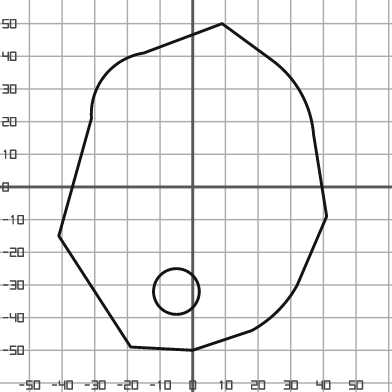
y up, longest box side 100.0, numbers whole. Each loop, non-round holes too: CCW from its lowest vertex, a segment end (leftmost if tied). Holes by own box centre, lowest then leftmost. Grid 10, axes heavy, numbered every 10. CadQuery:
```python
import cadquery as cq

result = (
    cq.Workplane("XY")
    .moveTo(0.0, -50.0)
    .lineTo(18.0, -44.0)
    .threePointArc((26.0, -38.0), (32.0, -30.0))
    .lineTo(41.0, -9.0)
    .lineTo(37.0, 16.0)
    .threePointArc((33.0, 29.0), (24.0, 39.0))
    .lineTo(9.0, 50.0)
    .lineTo(-15.0, 41.0)
    .threePointArc((-27.0, 34.0), (-31.0, 21.0))
    .lineTo(-41.0, -15.0)
    .lineTo(-19.0, -49.0)
    .close()
    .moveTo(-5.0, -32.0)
    .circle(7.0)
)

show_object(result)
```